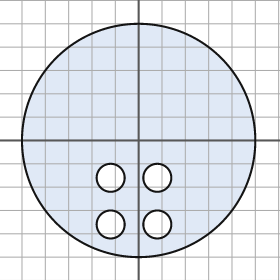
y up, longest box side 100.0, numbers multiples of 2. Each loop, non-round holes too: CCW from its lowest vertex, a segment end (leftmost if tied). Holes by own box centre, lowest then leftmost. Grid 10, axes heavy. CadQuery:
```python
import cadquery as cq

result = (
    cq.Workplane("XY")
    .moveTo(0.0, 0.0)
    .circle(50.0)
    .moveTo(-12.0, -36.0)
    .circle(6.0)
    .moveTo(8.0, -36.0)
    .circle(6.0)
    .moveTo(-12.0, -16.0)
    .circle(6.0)
    .moveTo(8.0, -16.0)
    .circle(6.0)
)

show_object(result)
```